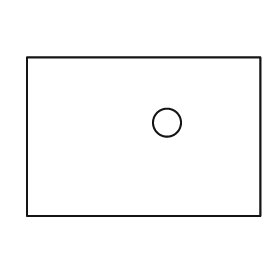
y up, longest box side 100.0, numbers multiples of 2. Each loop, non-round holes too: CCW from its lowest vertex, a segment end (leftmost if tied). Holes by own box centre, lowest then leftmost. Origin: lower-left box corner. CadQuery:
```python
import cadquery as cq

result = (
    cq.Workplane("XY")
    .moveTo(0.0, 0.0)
    .lineTo(100.0, 0.0)
    .lineTo(100.0, 68.0)
    .lineTo(0.0, 68.0)
    .close()
    .moveTo(60.0, 40.0)
    .circle(6.0)
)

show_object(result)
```